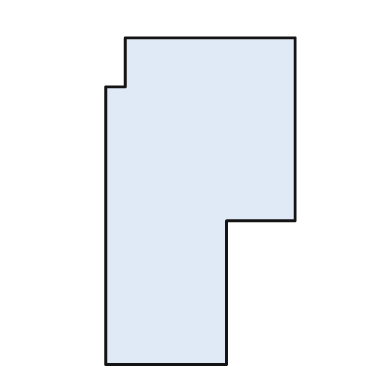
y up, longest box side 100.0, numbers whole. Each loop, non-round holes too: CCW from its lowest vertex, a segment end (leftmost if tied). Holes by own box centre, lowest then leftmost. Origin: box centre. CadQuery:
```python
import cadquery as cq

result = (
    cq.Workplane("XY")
    .moveTo(-29.0, -50.0)
    .lineTo(8.0, -50.0)
    .lineTo(8.0, -6.0)
    .lineTo(29.0, -6.0)
    .lineTo(29.0, 50.0)
    .lineTo(-23.0, 50.0)
    .lineTo(-23.0, 35.0)
    .lineTo(-29.0, 35.0)
    .close()
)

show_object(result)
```